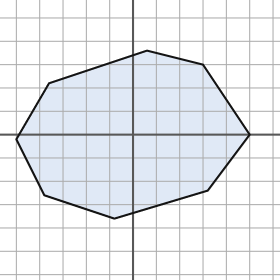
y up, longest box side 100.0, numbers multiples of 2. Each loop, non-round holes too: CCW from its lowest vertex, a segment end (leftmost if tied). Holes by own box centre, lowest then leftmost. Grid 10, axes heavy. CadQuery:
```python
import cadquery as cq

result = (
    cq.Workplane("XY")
    .moveTo(-8.0, -36.0)
    .lineTo(32.0, -24.0)
    .lineTo(50.0, 0.0)
    .lineTo(30.0, 30.0)
    .lineTo(6.0, 36.0)
    .lineTo(-36.0, 22.0)
    .lineTo(-50.0, -2.0)
    .lineTo(-38.0, -26.0)
    .close()
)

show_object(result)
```